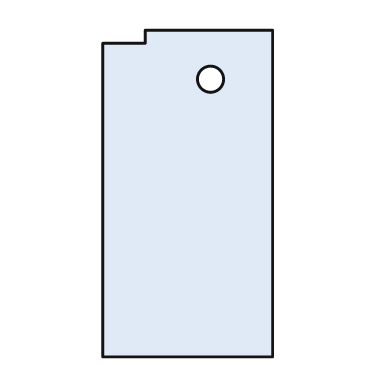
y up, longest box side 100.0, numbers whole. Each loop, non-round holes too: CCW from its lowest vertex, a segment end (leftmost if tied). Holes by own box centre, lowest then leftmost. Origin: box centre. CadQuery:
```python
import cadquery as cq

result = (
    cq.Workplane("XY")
    .moveTo(-26.0, -50.0)
    .lineTo(26.0, -50.0)
    .lineTo(26.0, 50.0)
    .lineTo(-13.0, 50.0)
    .lineTo(-13.0, 46.0)
    .lineTo(-26.0, 46.0)
    .close()
    .moveTo(7.0, 35.0)
    .circle(4.0)
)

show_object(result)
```